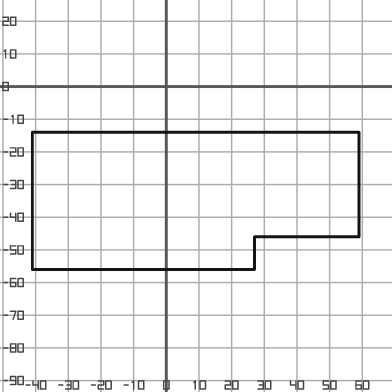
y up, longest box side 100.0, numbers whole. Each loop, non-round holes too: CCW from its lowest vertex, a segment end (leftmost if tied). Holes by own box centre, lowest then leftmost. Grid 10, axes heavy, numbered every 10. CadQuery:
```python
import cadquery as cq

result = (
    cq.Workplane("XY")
    .moveTo(-41.0, -56.0)
    .lineTo(27.0, -56.0)
    .lineTo(27.0, -46.0)
    .lineTo(59.0, -46.0)
    .lineTo(59.0, -14.0)
    .lineTo(-41.0, -14.0)
    .close()
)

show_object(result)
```